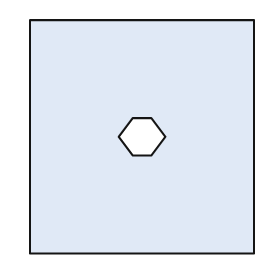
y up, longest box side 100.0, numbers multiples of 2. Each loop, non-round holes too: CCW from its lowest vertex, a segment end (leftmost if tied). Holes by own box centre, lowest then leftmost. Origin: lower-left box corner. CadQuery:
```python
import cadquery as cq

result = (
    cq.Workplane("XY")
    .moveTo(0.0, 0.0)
    .lineTo(96.0, 0.0)
    .lineTo(96.0, 100.0)
    .lineTo(0.0, 100.0)
    .close()
    .moveTo(44.0, 42.0)
    .lineTo(52.0, 42.0)
    .lineTo(58.0, 50.0)
    .lineTo(52.0, 58.0)
    .lineTo(44.0, 58.0)
    .lineTo(38.0, 50.0)
    .close()
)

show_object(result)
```